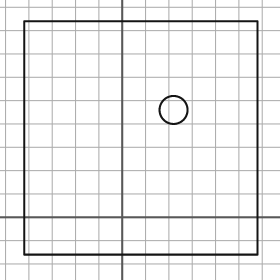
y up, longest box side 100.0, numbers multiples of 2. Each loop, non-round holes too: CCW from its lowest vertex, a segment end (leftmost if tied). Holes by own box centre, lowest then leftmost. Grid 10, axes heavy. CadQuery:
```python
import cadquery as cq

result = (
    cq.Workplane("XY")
    .moveTo(-42.0, -16.0)
    .lineTo(58.0, -16.0)
    .lineTo(58.0, 84.0)
    .lineTo(-42.0, 84.0)
    .close()
    .moveTo(22.0, 46.0)
    .circle(6.0)
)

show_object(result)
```